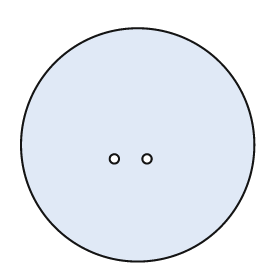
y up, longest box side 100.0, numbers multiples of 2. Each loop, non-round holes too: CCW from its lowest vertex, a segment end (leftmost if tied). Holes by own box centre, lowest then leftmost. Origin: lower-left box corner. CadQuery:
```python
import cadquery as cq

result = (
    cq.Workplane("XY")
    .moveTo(50.0, 50.0)
    .circle(50.0)
    .moveTo(40.0, 44.0)
    .circle(2.0)
    .moveTo(54.0, 44.0)
    .circle(2.0)
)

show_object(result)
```